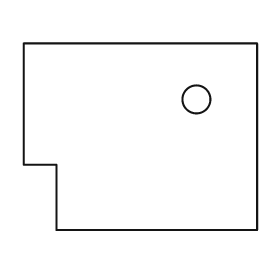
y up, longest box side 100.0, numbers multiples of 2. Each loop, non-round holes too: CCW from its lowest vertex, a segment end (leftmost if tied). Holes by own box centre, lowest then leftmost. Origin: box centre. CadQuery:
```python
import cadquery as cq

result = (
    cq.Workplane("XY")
    .moveTo(-36.0, -40.0)
    .lineTo(50.0, -40.0)
    .lineTo(50.0, 40.0)
    .lineTo(-50.0, 40.0)
    .lineTo(-50.0, -12.0)
    .lineTo(-36.0, -12.0)
    .close()
    .moveTo(24.0, 16.0)
    .circle(6.0)
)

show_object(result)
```